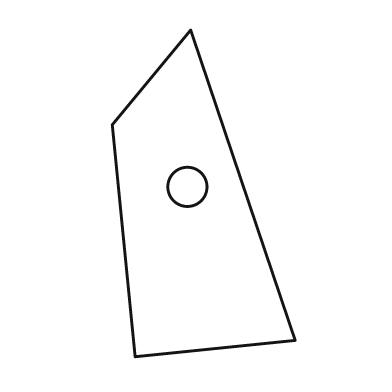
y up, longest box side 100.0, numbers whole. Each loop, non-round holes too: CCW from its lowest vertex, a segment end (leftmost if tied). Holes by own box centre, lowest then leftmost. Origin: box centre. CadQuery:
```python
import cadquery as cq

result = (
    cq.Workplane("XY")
    .moveTo(-21.0, -50.0)
    .lineTo(28.0, -45.0)
    .lineTo(-4.0, 50.0)
    .lineTo(-28.0, 21.0)
    .close()
    .moveTo(-5.0, 2.0)
    .circle(6.0)
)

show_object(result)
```